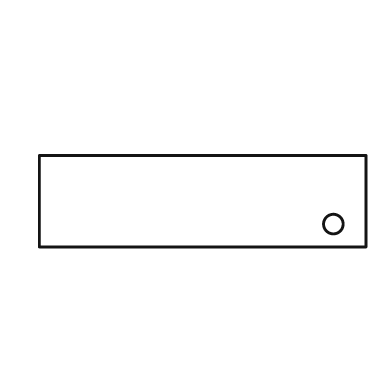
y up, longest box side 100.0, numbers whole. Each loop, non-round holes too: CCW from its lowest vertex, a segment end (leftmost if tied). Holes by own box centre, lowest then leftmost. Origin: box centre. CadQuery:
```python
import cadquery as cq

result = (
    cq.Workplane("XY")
    .moveTo(-50.0, -14.0)
    .lineTo(50.0, -14.0)
    .lineTo(50.0, 14.0)
    .lineTo(-50.0, 14.0)
    .close()
    .moveTo(40.0, -7.0)
    .circle(3.0)
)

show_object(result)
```